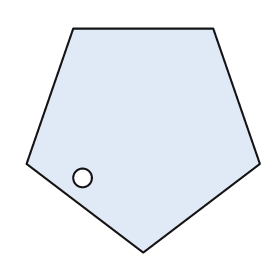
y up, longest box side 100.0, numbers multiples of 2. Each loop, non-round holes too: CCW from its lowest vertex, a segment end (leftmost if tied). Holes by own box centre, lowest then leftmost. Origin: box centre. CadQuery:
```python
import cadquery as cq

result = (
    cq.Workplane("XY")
    .moveTo(0.0, -48.0)
    .lineTo(50.0, -10.0)
    .lineTo(30.0, 48.0)
    .lineTo(-30.0, 48.0)
    .lineTo(-50.0, -10.0)
    .close()
    .moveTo(-26.0, -16.0)
    .circle(4.0)
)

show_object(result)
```